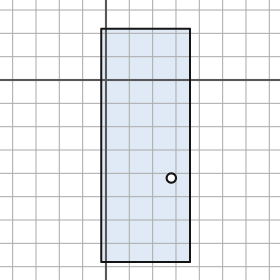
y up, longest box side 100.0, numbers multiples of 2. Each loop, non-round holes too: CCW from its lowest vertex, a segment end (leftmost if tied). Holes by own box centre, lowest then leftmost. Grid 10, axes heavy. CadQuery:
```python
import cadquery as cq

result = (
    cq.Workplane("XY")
    .moveTo(-2.0, -78.0)
    .lineTo(36.0, -78.0)
    .lineTo(36.0, 22.0)
    .lineTo(-2.0, 22.0)
    .close()
    .moveTo(28.0, -42.0)
    .circle(2.0)
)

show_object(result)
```